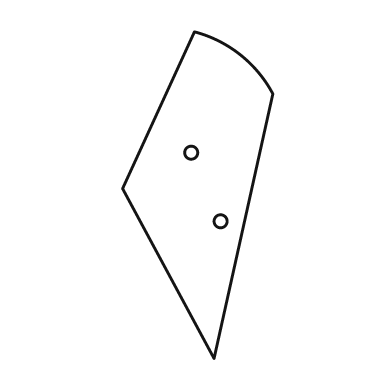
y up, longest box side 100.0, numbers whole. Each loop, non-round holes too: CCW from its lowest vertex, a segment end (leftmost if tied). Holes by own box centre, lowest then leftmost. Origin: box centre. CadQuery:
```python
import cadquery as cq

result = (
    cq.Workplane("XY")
    .moveTo(5.0, -50.0)
    .lineTo(23.0, 31.0)
    .threePointArc((13.0, 43.0), (-1.0, 50.0))
    .lineTo(-23.0, 2.0)
    .close()
    .moveTo(7.0, -8.0)
    .circle(2.0)
    .moveTo(-2.0, 13.0)
    .circle(2.0)
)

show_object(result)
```